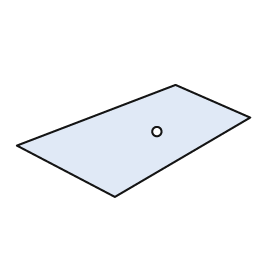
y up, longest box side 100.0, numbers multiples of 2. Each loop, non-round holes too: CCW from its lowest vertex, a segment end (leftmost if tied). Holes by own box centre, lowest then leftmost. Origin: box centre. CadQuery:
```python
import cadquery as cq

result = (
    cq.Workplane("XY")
    .moveTo(-8.0, -24.0)
    .lineTo(50.0, 10.0)
    .lineTo(18.0, 24.0)
    .lineTo(-50.0, -2.0)
    .close()
    .moveTo(10.0, 4.0)
    .circle(2.0)
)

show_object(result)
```